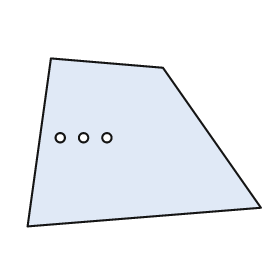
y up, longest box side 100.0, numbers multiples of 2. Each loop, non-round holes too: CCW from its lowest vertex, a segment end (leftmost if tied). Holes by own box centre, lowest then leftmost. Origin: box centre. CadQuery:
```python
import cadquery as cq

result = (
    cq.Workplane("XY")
    .moveTo(-50.0, -36.0)
    .lineTo(50.0, -28.0)
    .lineTo(8.0, 32.0)
    .lineTo(-40.0, 36.0)
    .close()
    .moveTo(-36.0, 2.0)
    .circle(2.0)
    .moveTo(-26.0, 2.0)
    .circle(2.0)
    .moveTo(-16.0, 2.0)
    .circle(2.0)
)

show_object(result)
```